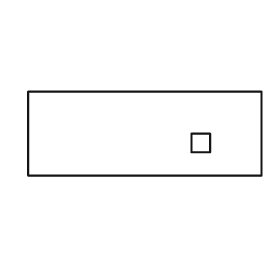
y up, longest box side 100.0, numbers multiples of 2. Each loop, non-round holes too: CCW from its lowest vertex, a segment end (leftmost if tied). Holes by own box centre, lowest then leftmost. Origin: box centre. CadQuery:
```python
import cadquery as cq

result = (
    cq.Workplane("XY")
    .moveTo(-50.0, -18.0)
    .lineTo(50.0, -18.0)
    .lineTo(50.0, 18.0)
    .lineTo(-50.0, 18.0)
    .close()
    .moveTo(20.0, -8.0)
    .lineTo(28.0, -8.0)
    .lineTo(28.0, 0.0)
    .lineTo(20.0, 0.0)
    .close()
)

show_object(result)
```